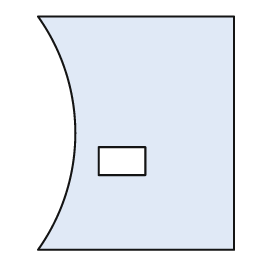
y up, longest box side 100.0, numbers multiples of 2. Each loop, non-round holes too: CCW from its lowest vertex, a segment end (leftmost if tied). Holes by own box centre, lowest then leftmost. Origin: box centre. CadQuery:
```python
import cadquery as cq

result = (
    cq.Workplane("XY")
    .moveTo(-42.0, -50.0)
    .lineTo(42.0, -50.0)
    .lineTo(42.0, 50.0)
    .lineTo(-42.0, 50.0)
    .threePointArc((-26.0, 0.0), (-42.0, -50.0))
    .close()
    .moveTo(-16.0, -18.0)
    .lineTo(4.0, -18.0)
    .lineTo(4.0, -6.0)
    .lineTo(-16.0, -6.0)
    .close()
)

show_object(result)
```